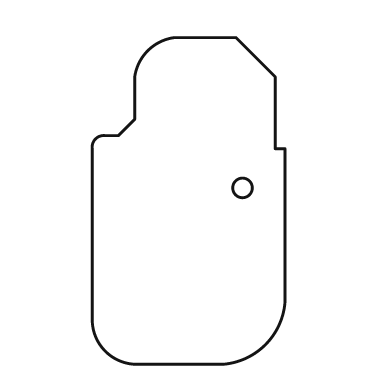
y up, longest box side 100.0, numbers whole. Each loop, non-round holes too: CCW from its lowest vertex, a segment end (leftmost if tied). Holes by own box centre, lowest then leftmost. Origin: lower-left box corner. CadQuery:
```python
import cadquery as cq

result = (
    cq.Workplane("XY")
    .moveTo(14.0, 0.0)
    .lineTo(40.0, 0.0)
    .threePointArc((53.0, 6.0), (59.0, 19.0))
    .lineTo(59.0, 66.0)
    .lineTo(56.0, 66.0)
    .lineTo(56.0, 88.0)
    .lineTo(44.0, 100.0)
    .lineTo(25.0, 100.0)
    .threePointArc((17.0, 96.0), (13.0, 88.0))
    .lineTo(13.0, 75.0)
    .lineTo(8.0, 70.0)
    .lineTo(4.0, 70.0)
    .threePointArc((1.0, 69.0), (0.0, 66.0))
    .lineTo(0.0, 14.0)
    .threePointArc((4.0, 4.0), (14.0, 0.0))
    .close()
    .moveTo(46.0, 54.0)
    .circle(3.0)
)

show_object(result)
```